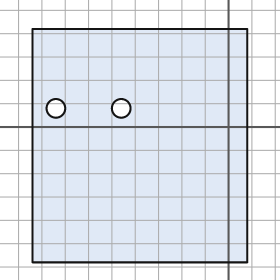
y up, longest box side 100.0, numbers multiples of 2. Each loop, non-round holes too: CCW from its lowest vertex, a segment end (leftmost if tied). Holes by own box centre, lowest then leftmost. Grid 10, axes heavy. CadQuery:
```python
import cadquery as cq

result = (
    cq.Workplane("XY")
    .moveTo(-84.0, -58.0)
    .lineTo(8.0, -58.0)
    .lineTo(8.0, 42.0)
    .lineTo(-84.0, 42.0)
    .close()
    .moveTo(-74.0, 8.0)
    .circle(4.0)
    .moveTo(-46.0, 8.0)
    .circle(4.0)
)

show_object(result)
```